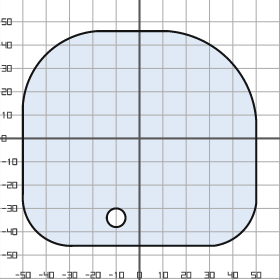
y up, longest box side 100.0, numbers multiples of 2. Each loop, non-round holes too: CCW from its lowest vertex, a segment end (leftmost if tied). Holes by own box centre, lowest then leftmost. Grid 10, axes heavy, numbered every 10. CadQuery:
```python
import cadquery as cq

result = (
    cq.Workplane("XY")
    .moveTo(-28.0, -46.0)
    .lineTo(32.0, -46.0)
    .threePointArc((44.0, -40.0), (50.0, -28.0))
    .lineTo(50.0, 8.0)
    .threePointArc((38.0, 34.0), (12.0, 46.0))
    .lineTo(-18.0, 46.0)
    .threePointArc((-40.0, 36.0), (-50.0, 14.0))
    .lineTo(-50.0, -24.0)
    .threePointArc((-44.0, -40.0), (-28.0, -46.0))
    .close()
    .moveTo(-10.0, -34.0)
    .circle(4.0)
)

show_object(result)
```